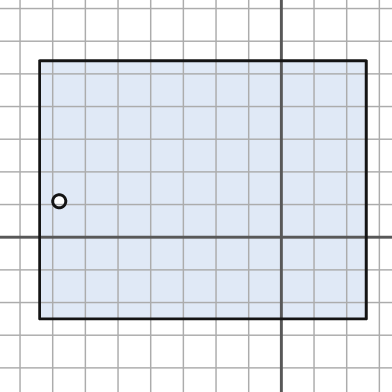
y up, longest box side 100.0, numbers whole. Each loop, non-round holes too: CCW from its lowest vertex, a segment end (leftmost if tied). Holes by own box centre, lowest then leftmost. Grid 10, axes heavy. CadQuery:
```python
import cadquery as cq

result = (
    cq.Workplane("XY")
    .moveTo(-74.0, -25.0)
    .lineTo(26.0, -25.0)
    .lineTo(26.0, 54.0)
    .lineTo(-74.0, 54.0)
    .close()
    .moveTo(-68.0, 11.0)
    .circle(2.0)
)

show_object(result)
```